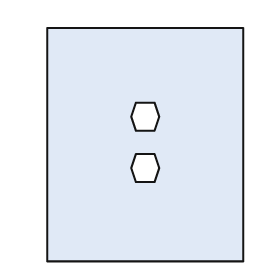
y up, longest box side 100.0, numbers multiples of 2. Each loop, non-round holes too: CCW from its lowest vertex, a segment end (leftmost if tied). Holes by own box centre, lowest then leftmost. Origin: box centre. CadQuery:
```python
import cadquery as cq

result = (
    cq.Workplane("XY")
    .moveTo(-42.0, -50.0)
    .lineTo(42.0, -50.0)
    .lineTo(42.0, 50.0)
    .lineTo(-42.0, 50.0)
    .close()
    .moveTo(-4.0, -16.0)
    .lineTo(4.0, -16.0)
    .lineTo(6.0, -10.0)
    .lineTo(4.0, -4.0)
    .lineTo(-4.0, -4.0)
    .lineTo(-6.0, -10.0)
    .close()
    .moveTo(-4.0, 6.0)
    .lineTo(4.0, 6.0)
    .lineTo(6.0, 12.0)
    .lineTo(4.0, 18.0)
    .lineTo(-4.0, 18.0)
    .lineTo(-6.0, 12.0)
    .close()
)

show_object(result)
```